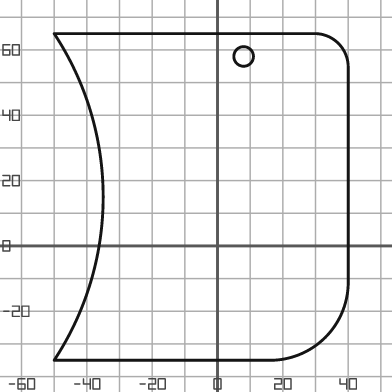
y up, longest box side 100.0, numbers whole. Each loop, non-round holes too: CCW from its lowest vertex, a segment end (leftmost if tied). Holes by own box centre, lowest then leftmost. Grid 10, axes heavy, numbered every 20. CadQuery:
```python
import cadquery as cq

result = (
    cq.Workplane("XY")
    .moveTo(-50.0, -35.0)
    .lineTo(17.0, -35.0)
    .threePointArc((33.0, -28.0), (40.0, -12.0))
    .lineTo(40.0, 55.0)
    .threePointArc((37.0, 62.0), (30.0, 65.0))
    .lineTo(-50.0, 65.0)
    .threePointArc((-35.0, 15.0), (-50.0, -35.0))
    .close()
    .moveTo(8.0, 58.0)
    .circle(3.0)
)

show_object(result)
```